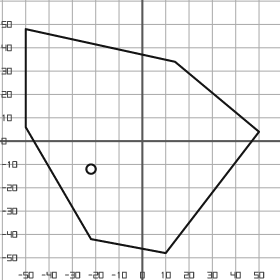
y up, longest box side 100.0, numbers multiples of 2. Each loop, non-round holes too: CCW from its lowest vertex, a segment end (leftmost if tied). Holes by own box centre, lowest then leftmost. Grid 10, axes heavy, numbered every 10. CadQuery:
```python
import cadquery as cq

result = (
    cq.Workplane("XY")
    .moveTo(10.0, -48.0)
    .lineTo(50.0, 4.0)
    .lineTo(14.0, 34.0)
    .lineTo(-50.0, 48.0)
    .lineTo(-50.0, 6.0)
    .lineTo(-22.0, -42.0)
    .close()
    .moveTo(-22.0, -12.0)
    .circle(2.0)
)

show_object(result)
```